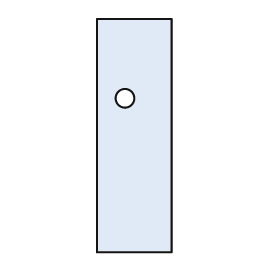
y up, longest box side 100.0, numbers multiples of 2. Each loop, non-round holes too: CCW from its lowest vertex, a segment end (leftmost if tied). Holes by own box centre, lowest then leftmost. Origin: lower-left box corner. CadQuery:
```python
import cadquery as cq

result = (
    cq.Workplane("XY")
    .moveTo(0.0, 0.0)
    .lineTo(32.0, 0.0)
    .lineTo(32.0, 100.0)
    .lineTo(0.0, 100.0)
    .close()
    .moveTo(12.0, 66.0)
    .circle(4.0)
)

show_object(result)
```